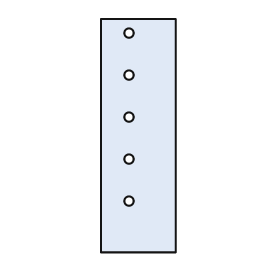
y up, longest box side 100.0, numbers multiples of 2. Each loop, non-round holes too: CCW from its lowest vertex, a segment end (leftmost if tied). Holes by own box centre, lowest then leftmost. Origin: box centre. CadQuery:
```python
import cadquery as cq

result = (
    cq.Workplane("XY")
    .moveTo(-16.0, -50.0)
    .lineTo(16.0, -50.0)
    .lineTo(16.0, 50.0)
    .lineTo(-16.0, 50.0)
    .close()
    .moveTo(-4.0, -28.0)
    .circle(2.0)
    .moveTo(-4.0, -10.0)
    .circle(2.0)
    .moveTo(-4.0, 8.0)
    .circle(2.0)
    .moveTo(-4.0, 26.0)
    .circle(2.0)
    .moveTo(-4.0, 44.0)
    .circle(2.0)
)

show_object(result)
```